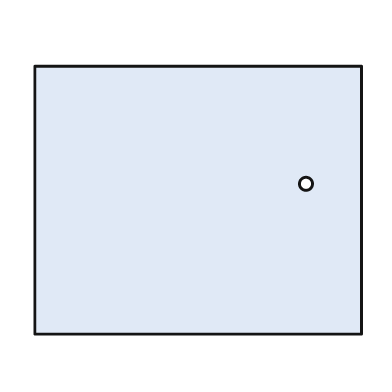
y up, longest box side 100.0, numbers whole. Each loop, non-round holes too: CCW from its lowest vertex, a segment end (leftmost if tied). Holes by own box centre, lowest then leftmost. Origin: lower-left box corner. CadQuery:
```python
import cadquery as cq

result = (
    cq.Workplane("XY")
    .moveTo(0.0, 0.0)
    .lineTo(100.0, 0.0)
    .lineTo(100.0, 82.0)
    .lineTo(0.0, 82.0)
    .close()
    .moveTo(83.0, 46.0)
    .circle(2.0)
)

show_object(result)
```